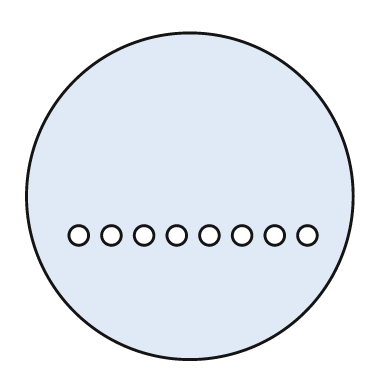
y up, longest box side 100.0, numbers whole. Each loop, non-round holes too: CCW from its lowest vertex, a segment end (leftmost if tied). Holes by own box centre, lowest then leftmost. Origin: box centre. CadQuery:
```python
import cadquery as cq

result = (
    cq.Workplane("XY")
    .moveTo(0.0, 0.0)
    .circle(50.0)
    .moveTo(-34.0, -12.0)
    .circle(3.0)
    .moveTo(-24.0, -12.0)
    .circle(3.0)
    .moveTo(-14.0, -12.0)
    .circle(3.0)
    .moveTo(-4.0, -12.0)
    .circle(3.0)
    .moveTo(6.0, -12.0)
    .circle(3.0)
    .moveTo(16.0, -12.0)
    .circle(3.0)
    .moveTo(26.0, -12.0)
    .circle(3.0)
    .moveTo(36.0, -12.0)
    .circle(3.0)
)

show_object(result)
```